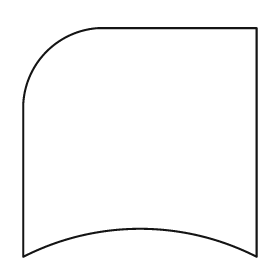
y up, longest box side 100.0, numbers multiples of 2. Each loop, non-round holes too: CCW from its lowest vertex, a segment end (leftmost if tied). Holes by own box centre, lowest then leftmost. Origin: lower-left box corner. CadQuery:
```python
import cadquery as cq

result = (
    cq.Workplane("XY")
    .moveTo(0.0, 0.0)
    .threePointArc((50.0, 12.0), (100.0, 0.0))
    .lineTo(100.0, 98.0)
    .lineTo(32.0, 98.0)
    .threePointArc((10.0, 88.0), (0.0, 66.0))
    .close()
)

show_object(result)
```